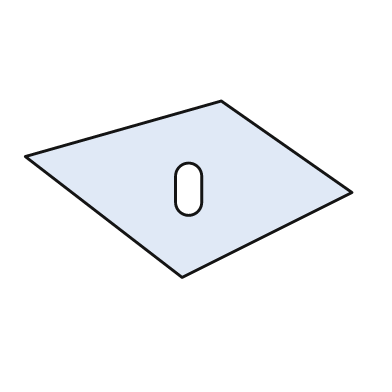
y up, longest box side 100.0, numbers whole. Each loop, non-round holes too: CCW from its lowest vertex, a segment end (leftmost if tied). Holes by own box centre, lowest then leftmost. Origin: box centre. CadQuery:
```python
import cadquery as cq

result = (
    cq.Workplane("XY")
    .moveTo(-2.0, -27.0)
    .lineTo(50.0, -1.0)
    .lineTo(10.0, 27.0)
    .lineTo(-50.0, 10.0)
    .close()
    .moveTo(-4.0, -4.0)
    .threePointArc((0.0, -8.0), (4.0, -4.0))
    .lineTo(4.0, 4.0)
    .threePointArc((0.0, 8.0), (-4.0, 4.0))
    .close()
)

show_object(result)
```